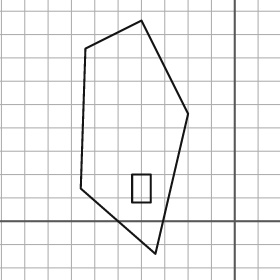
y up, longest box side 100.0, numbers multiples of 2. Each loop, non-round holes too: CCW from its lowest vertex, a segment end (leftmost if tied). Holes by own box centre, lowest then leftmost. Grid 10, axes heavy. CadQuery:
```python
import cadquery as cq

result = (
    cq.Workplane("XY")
    .moveTo(-34.0, -14.0)
    .lineTo(-20.0, 46.0)
    .lineTo(-40.0, 86.0)
    .lineTo(-64.0, 74.0)
    .lineTo(-66.0, 14.0)
    .close()
    .moveTo(-44.0, 8.0)
    .lineTo(-36.0, 8.0)
    .lineTo(-36.0, 20.0)
    .lineTo(-44.0, 20.0)
    .close()
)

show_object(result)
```